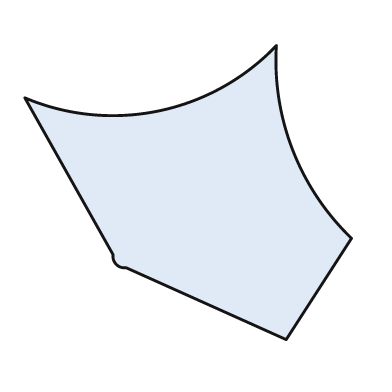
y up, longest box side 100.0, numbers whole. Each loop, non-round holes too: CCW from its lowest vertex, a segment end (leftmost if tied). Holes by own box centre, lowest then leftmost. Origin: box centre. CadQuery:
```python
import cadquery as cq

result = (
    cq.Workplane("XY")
    .moveTo(30.0, -45.0)
    .lineTo(50.0, -14.0)
    .threePointArc((32.0, 13.0), (27.0, 45.0))
    .threePointArc((-9.0, 25.0), (-50.0, 29.0))
    .lineTo(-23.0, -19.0)
    .threePointArc((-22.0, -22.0), (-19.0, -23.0))
    .close()
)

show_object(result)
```